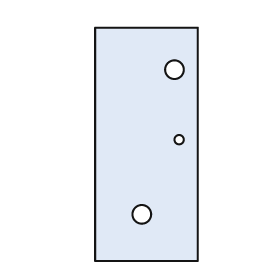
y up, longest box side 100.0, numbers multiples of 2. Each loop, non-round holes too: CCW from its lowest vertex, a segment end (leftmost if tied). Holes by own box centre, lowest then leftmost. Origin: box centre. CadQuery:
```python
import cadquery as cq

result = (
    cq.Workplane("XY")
    .moveTo(-22.0, -50.0)
    .lineTo(22.0, -50.0)
    .lineTo(22.0, 50.0)
    .lineTo(-22.0, 50.0)
    .close()
    .moveTo(-2.0, -30.0)
    .circle(4.0)
    .moveTo(14.0, 2.0)
    .circle(2.0)
    .moveTo(12.0, 32.0)
    .circle(4.0)
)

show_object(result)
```